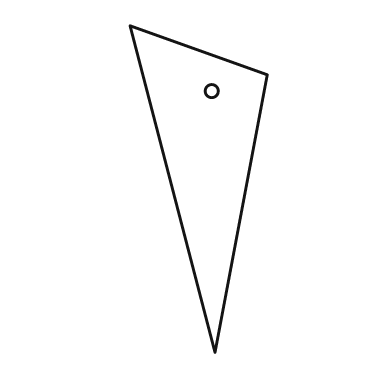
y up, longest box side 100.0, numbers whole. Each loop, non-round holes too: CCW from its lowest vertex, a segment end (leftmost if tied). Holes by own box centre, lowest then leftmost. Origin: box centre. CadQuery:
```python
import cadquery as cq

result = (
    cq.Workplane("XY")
    .moveTo(5.0, -50.0)
    .lineTo(21.0, 35.0)
    .lineTo(-21.0, 50.0)
    .close()
    .moveTo(4.0, 30.0)
    .circle(2.0)
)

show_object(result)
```